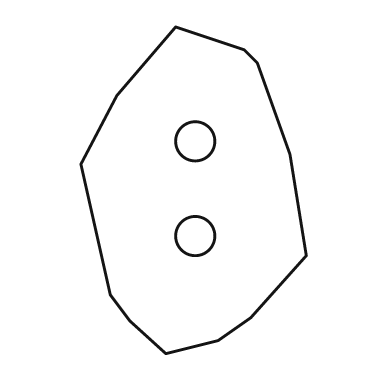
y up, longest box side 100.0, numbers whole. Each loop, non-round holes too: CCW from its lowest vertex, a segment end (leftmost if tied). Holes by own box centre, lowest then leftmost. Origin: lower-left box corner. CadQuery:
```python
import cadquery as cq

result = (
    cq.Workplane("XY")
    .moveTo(26.0, 0.0)
    .lineTo(42.0, 4.0)
    .lineTo(52.0, 11.0)
    .lineTo(69.0, 30.0)
    .lineTo(64.0, 61.0)
    .lineTo(54.0, 89.0)
    .lineTo(50.0, 93.0)
    .lineTo(29.0, 100.0)
    .lineTo(11.0, 79.0)
    .lineTo(0.0, 58.0)
    .lineTo(9.0, 18.0)
    .lineTo(15.0, 10.0)
    .close()
    .moveTo(35.0, 36.0)
    .circle(6.0)
    .moveTo(35.0, 65.0)
    .circle(6.0)
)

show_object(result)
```